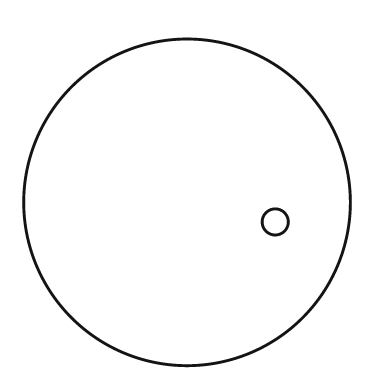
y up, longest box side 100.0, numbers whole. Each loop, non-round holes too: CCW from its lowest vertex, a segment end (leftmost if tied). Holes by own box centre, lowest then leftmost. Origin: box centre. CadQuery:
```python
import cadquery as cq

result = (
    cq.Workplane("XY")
    .moveTo(0.0, 0.0)
    .circle(50.0)
    .moveTo(27.0, -6.0)
    .circle(4.0)
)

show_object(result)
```